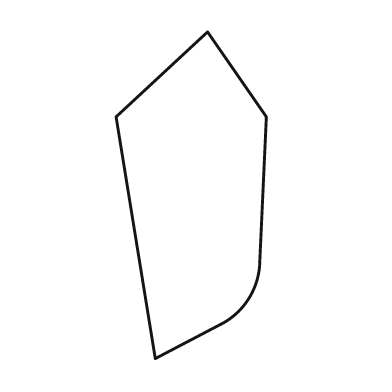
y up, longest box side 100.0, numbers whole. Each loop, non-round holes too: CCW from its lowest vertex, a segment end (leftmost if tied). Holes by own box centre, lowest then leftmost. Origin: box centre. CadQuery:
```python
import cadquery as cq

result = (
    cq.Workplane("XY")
    .moveTo(-11.0, -50.0)
    .lineTo(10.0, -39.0)
    .threePointArc((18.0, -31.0), (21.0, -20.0))
    .lineTo(23.0, 24.0)
    .lineTo(5.0, 50.0)
    .lineTo(-23.0, 24.0)
    .close()
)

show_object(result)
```